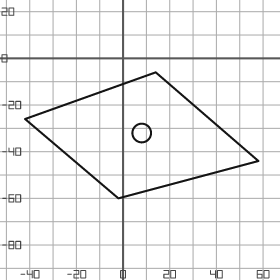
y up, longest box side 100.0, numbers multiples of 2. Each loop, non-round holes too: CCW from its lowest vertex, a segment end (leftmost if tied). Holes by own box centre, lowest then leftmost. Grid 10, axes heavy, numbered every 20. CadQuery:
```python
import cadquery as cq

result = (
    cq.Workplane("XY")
    .moveTo(-2.0, -60.0)
    .lineTo(58.0, -44.0)
    .lineTo(14.0, -6.0)
    .lineTo(-42.0, -26.0)
    .close()
    .moveTo(8.0, -32.0)
    .circle(4.0)
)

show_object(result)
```